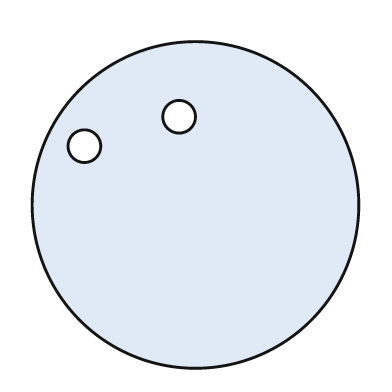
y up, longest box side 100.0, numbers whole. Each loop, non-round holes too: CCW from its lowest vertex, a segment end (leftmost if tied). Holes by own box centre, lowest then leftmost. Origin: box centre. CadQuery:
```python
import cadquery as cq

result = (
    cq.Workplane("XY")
    .moveTo(0.0, 0.0)
    .circle(50.0)
    .moveTo(-34.0, 18.0)
    .circle(5.0)
    .moveTo(-5.0, 27.0)
    .circle(5.0)
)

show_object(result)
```